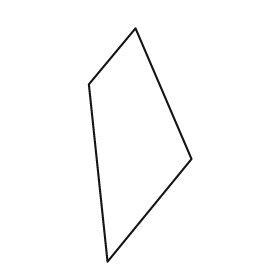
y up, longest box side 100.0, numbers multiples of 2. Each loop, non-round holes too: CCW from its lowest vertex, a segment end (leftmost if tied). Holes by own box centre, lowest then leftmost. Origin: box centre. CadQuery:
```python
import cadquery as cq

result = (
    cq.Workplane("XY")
    .moveTo(-14.0, -50.0)
    .lineTo(22.0, -6.0)
    .lineTo(-2.0, 50.0)
    .lineTo(-22.0, 26.0)
    .close()
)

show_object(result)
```